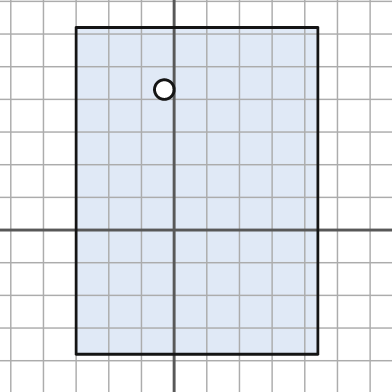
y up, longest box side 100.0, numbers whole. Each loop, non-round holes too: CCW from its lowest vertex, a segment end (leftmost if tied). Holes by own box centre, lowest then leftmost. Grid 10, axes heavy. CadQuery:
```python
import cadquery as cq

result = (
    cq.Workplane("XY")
    .moveTo(-30.0, -38.0)
    .lineTo(44.0, -38.0)
    .lineTo(44.0, 62.0)
    .lineTo(-30.0, 62.0)
    .close()
    .moveTo(-3.0, 43.0)
    .circle(3.0)
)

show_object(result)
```